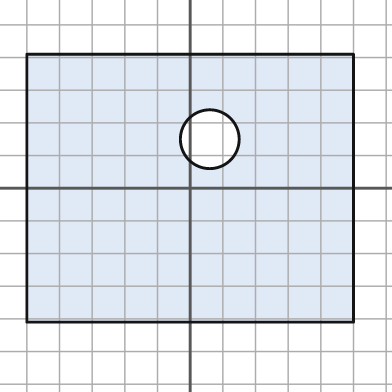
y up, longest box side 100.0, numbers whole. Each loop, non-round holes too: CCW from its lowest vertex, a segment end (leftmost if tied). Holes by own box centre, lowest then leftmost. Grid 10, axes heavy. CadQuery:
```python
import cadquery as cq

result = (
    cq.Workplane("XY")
    .moveTo(-50.0, -41.0)
    .lineTo(50.0, -41.0)
    .lineTo(50.0, 41.0)
    .lineTo(-50.0, 41.0)
    .close()
    .moveTo(6.0, 15.0)
    .circle(9.0)
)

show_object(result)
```